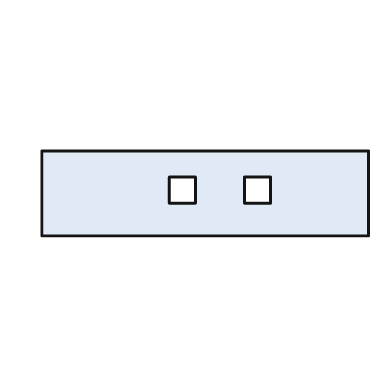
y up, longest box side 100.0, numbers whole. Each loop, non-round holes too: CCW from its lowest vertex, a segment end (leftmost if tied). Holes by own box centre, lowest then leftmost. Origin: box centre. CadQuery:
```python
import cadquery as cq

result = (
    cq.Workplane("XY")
    .moveTo(-50.0, -13.0)
    .lineTo(50.0, -13.0)
    .lineTo(50.0, 13.0)
    .lineTo(-50.0, 13.0)
    .close()
    .moveTo(-11.0, -3.0)
    .lineTo(-3.0, -3.0)
    .lineTo(-3.0, 5.0)
    .lineTo(-11.0, 5.0)
    .close()
    .moveTo(12.0, -3.0)
    .lineTo(20.0, -3.0)
    .lineTo(20.0, 5.0)
    .lineTo(12.0, 5.0)
    .close()
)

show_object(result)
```